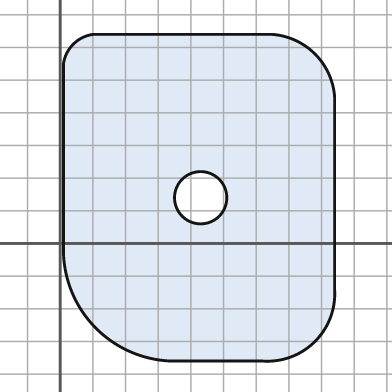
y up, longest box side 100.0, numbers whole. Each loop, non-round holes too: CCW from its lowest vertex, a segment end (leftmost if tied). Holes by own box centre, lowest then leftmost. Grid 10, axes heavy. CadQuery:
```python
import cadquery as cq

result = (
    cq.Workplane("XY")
    .moveTo(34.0, -36.0)
    .lineTo(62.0, -36.0)
    .threePointArc((78.0, -30.0), (84.0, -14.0))
    .lineTo(84.0, 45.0)
    .threePointArc((78.0, 58.0), (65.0, 64.0))
    .lineTo(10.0, 64.0)
    .threePointArc((4.0, 61.0), (1.0, 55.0))
    .lineTo(1.0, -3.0)
    .threePointArc((11.0, -26.0), (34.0, -36.0))
    .close()
    .moveTo(43.0, 14.0)
    .circle(8.0)
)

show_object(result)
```